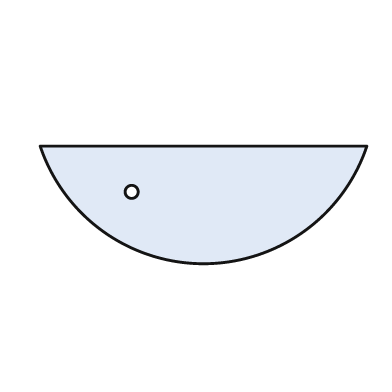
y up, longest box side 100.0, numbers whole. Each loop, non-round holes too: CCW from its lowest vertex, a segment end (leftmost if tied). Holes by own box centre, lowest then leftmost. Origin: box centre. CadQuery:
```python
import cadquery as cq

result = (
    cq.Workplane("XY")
    .moveTo(-50.0, 18.0)
    .threePointArc((0.0, -18.0), (50.0, 18.0))
    .close()
    .moveTo(-22.0, 4.0)
    .circle(2.0)
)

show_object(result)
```